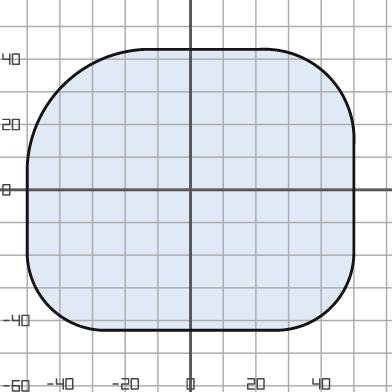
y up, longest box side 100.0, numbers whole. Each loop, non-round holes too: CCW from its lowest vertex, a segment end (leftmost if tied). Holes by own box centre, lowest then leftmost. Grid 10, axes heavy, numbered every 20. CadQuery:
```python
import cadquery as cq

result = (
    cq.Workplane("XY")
    .moveTo(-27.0, -43.0)
    .lineTo(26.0, -43.0)
    .threePointArc((43.0, -36.0), (50.0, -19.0))
    .lineTo(50.0, 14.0)
    .threePointArc((42.0, 35.0), (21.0, 43.0))
    .lineTo(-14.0, 43.0)
    .threePointArc((-39.0, 32.0), (-50.0, 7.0))
    .lineTo(-50.0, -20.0)
    .threePointArc((-43.0, -36.0), (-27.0, -43.0))
    .close()
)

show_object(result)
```